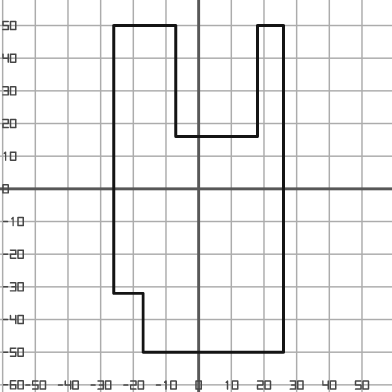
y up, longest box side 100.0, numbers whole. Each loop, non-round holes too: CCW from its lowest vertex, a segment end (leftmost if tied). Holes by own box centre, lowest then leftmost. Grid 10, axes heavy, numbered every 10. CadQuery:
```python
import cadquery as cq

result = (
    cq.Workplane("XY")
    .moveTo(-17.0, -50.0)
    .lineTo(26.0, -50.0)
    .lineTo(26.0, 50.0)
    .lineTo(18.0, 50.0)
    .lineTo(18.0, 16.0)
    .lineTo(-7.0, 16.0)
    .lineTo(-7.0, 50.0)
    .lineTo(-26.0, 50.0)
    .lineTo(-26.0, -32.0)
    .lineTo(-17.0, -32.0)
    .close()
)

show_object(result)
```